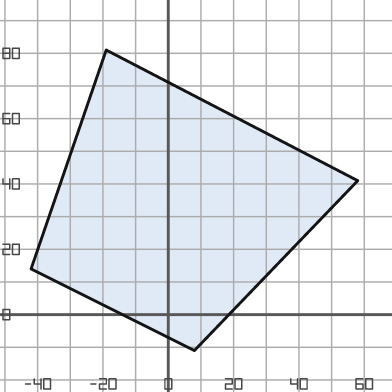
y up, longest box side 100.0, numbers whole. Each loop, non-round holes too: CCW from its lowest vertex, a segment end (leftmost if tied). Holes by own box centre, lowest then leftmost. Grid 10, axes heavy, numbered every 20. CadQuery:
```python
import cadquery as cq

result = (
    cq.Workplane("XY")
    .moveTo(8.0, -11.0)
    .lineTo(58.0, 41.0)
    .lineTo(-19.0, 81.0)
    .lineTo(-42.0, 14.0)
    .close()
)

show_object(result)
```